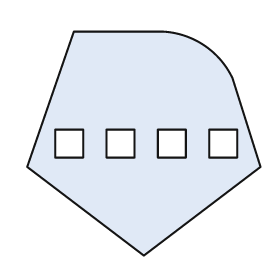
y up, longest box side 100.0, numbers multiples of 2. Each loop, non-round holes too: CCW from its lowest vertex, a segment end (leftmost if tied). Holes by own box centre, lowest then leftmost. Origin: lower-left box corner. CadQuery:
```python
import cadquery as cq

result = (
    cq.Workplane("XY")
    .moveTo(50.0, 0.0)
    .lineTo(100.0, 38.0)
    .lineTo(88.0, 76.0)
    .threePointArc((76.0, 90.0), (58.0, 96.0))
    .lineTo(20.0, 96.0)
    .lineTo(0.0, 38.0)
    .close()
    .moveTo(12.0, 42.0)
    .lineTo(24.0, 42.0)
    .lineTo(24.0, 54.0)
    .lineTo(12.0, 54.0)
    .close()
    .moveTo(34.0, 42.0)
    .lineTo(46.0, 42.0)
    .lineTo(46.0, 54.0)
    .lineTo(34.0, 54.0)
    .close()
    .moveTo(56.0, 42.0)
    .lineTo(68.0, 42.0)
    .lineTo(68.0, 54.0)
    .lineTo(56.0, 54.0)
    .close()
    .moveTo(78.0, 42.0)
    .lineTo(90.0, 42.0)
    .lineTo(90.0, 54.0)
    .lineTo(78.0, 54.0)
    .close()
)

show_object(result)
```